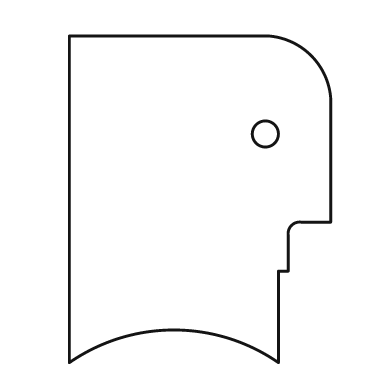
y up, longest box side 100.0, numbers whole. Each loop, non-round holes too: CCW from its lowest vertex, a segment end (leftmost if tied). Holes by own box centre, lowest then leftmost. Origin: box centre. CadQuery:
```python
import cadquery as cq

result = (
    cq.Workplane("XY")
    .moveTo(-40.0, -50.0)
    .threePointArc((-8.0, -40.0), (24.0, -50.0))
    .lineTo(24.0, -22.0)
    .lineTo(27.0, -22.0)
    .lineTo(27.0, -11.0)
    .threePointArc((28.0, -8.0), (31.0, -7.0))
    .lineTo(40.0, -7.0)
    .lineTo(40.0, 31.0)
    .threePointArc((34.0, 44.0), (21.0, 50.0))
    .lineTo(-40.0, 50.0)
    .close()
    .moveTo(20.0, 20.0)
    .circle(4.0)
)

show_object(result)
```